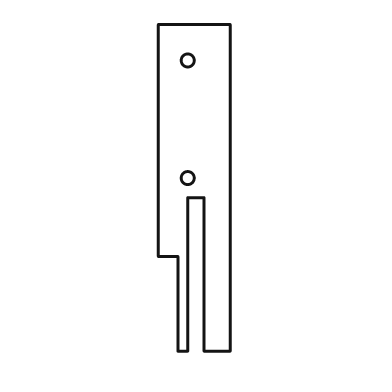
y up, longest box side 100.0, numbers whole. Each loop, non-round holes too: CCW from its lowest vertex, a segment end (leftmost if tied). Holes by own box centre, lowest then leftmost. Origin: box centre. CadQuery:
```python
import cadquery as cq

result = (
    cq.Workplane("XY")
    .moveTo(-5.0, -50.0)
    .lineTo(-2.0, -50.0)
    .lineTo(-2.0, -3.0)
    .lineTo(3.0, -3.0)
    .lineTo(3.0, -50.0)
    .lineTo(11.0, -50.0)
    .lineTo(11.0, 50.0)
    .lineTo(-11.0, 50.0)
    .lineTo(-11.0, -21.0)
    .lineTo(-5.0, -21.0)
    .close()
    .moveTo(-2.0, 3.0)
    .circle(2.0)
    .moveTo(-2.0, 39.0)
    .circle(2.0)
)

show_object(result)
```